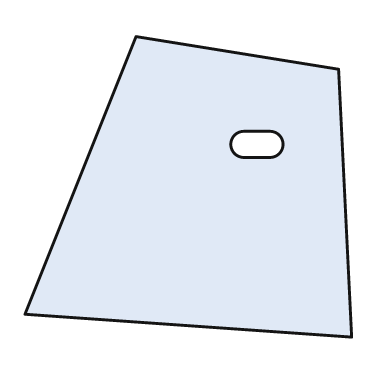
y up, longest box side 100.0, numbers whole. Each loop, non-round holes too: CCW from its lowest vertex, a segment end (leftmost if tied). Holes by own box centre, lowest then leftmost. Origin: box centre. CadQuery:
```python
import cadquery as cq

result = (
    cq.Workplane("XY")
    .moveTo(50.0, -46.0)
    .lineTo(46.0, 36.0)
    .lineTo(-16.0, 46.0)
    .lineTo(-50.0, -39.0)
    .close()
    .moveTo(17.0, 9.0)
    .lineTo(25.0, 9.0)
    .threePointArc((29.0, 13.0), (25.0, 17.0))
    .lineTo(17.0, 17.0)
    .threePointArc((13.0, 13.0), (17.0, 9.0))
    .close()
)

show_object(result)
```